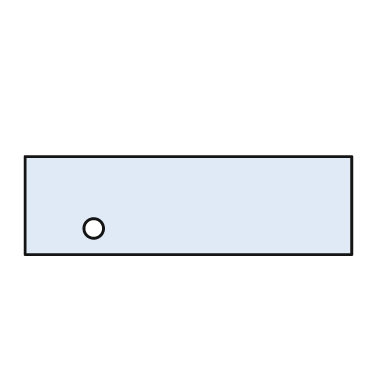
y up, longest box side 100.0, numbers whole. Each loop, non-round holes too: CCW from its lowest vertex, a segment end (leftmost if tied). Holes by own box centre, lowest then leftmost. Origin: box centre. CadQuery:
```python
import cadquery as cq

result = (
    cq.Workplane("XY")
    .moveTo(-50.0, -15.0)
    .lineTo(50.0, -15.0)
    .lineTo(50.0, 15.0)
    .lineTo(-50.0, 15.0)
    .close()
    .moveTo(-29.0, -7.0)
    .circle(3.0)
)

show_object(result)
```